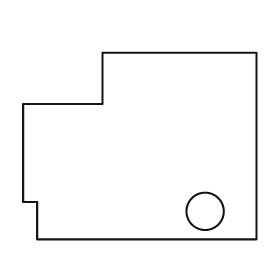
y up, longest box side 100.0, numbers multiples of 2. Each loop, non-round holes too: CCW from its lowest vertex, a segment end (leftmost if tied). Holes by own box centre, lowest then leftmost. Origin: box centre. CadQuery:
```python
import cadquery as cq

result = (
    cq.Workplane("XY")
    .moveTo(-44.0, -40.0)
    .lineTo(50.0, -40.0)
    .lineTo(50.0, 40.0)
    .lineTo(-16.0, 40.0)
    .lineTo(-16.0, 18.0)
    .lineTo(-50.0, 18.0)
    .lineTo(-50.0, -24.0)
    .lineTo(-44.0, -24.0)
    .close()
    .moveTo(28.0, -28.0)
    .circle(8.0)
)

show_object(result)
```